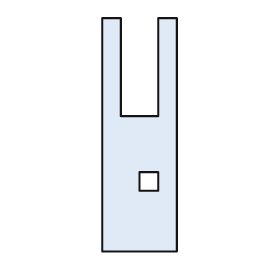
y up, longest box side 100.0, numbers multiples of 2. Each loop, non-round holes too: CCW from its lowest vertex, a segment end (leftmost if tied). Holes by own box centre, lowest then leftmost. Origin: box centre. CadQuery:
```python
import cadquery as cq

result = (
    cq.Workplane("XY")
    .moveTo(-16.0, -50.0)
    .lineTo(16.0, -50.0)
    .lineTo(16.0, 50.0)
    .lineTo(8.0, 50.0)
    .lineTo(8.0, 8.0)
    .lineTo(-8.0, 8.0)
    .lineTo(-8.0, 50.0)
    .lineTo(-16.0, 50.0)
    .close()
    .moveTo(0.0, -24.0)
    .lineTo(8.0, -24.0)
    .lineTo(8.0, -16.0)
    .lineTo(0.0, -16.0)
    .close()
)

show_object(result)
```